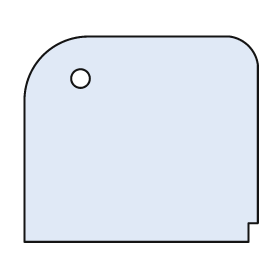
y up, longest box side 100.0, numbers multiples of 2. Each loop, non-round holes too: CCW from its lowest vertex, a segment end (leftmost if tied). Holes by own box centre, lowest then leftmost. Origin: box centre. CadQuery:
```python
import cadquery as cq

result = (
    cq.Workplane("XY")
    .moveTo(-50.0, -44.0)
    .lineTo(46.0, -44.0)
    .lineTo(46.0, -36.0)
    .lineTo(50.0, -36.0)
    .lineTo(50.0, 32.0)
    .threePointArc((46.0, 40.0), (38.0, 44.0))
    .lineTo(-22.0, 44.0)
    .threePointArc((-42.0, 36.0), (-50.0, 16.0))
    .close()
    .moveTo(-26.0, 26.0)
    .circle(4.0)
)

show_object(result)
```